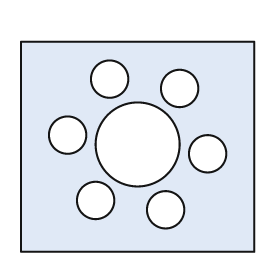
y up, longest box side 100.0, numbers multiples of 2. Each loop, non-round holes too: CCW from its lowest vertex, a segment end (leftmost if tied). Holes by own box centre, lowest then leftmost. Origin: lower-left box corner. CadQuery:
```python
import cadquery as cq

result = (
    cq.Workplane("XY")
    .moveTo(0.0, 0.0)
    .lineTo(100.0, 0.0)
    .lineTo(100.0, 90.0)
    .lineTo(0.0, 90.0)
    .close()
    .moveTo(62.0, 18.0)
    .circle(8.0)
    .moveTo(32.0, 22.0)
    .circle(8.0)
    .moveTo(80.0, 42.0)
    .circle(8.0)
    .moveTo(50.0, 46.0)
    .circle(18.0)
    .moveTo(20.0, 50.0)
    .circle(8.0)
    .moveTo(68.0, 70.0)
    .circle(8.0)
    .moveTo(38.0, 74.0)
    .circle(8.0)
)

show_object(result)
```